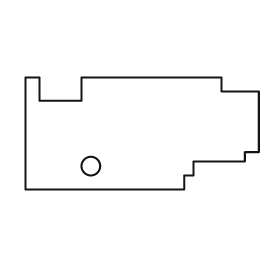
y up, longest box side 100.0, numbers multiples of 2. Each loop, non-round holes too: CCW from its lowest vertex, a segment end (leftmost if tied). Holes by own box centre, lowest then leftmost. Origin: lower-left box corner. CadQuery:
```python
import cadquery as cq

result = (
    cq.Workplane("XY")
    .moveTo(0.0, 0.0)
    .lineTo(68.0, 0.0)
    .lineTo(68.0, 6.0)
    .lineTo(72.0, 6.0)
    .lineTo(72.0, 12.0)
    .lineTo(94.0, 12.0)
    .lineTo(94.0, 16.0)
    .lineTo(100.0, 16.0)
    .lineTo(100.0, 42.0)
    .lineTo(84.0, 42.0)
    .lineTo(84.0, 48.0)
    .lineTo(24.0, 48.0)
    .lineTo(24.0, 38.0)
    .lineTo(6.0, 38.0)
    .lineTo(6.0, 48.0)
    .lineTo(0.0, 48.0)
    .close()
    .moveTo(28.0, 10.0)
    .circle(4.0)
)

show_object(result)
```